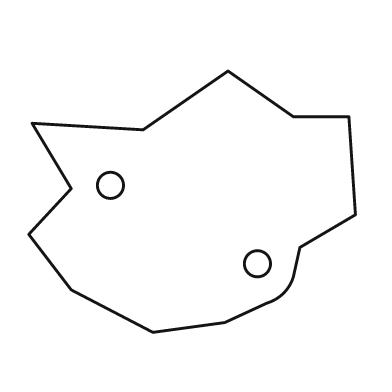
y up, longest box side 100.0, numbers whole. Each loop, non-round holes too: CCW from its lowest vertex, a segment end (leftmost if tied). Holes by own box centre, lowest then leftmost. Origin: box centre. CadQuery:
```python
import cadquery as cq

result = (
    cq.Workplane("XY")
    .moveTo(-12.0, -40.0)
    .lineTo(10.0, -37.0)
    .lineTo(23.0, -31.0)
    .threePointArc((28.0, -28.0), (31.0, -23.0))
    .lineTo(33.0, -14.0)
    .lineTo(50.0, -4.0)
    .lineTo(48.0, 26.0)
    .lineTo(31.0, 26.0)
    .lineTo(11.0, 40.0)
    .lineTo(-15.0, 22.0)
    .lineTo(-49.0, 24.0)
    .lineTo(-37.0, 4.0)
    .lineTo(-50.0, -10.0)
    .lineTo(-37.0, -27.0)
    .close()
    .moveTo(20.0, -19.0)
    .circle(4.0)
    .moveTo(-25.0, 5.0)
    .circle(4.0)
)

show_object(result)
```